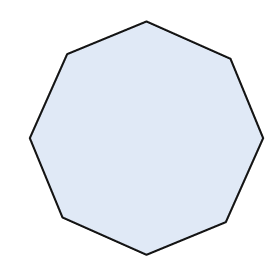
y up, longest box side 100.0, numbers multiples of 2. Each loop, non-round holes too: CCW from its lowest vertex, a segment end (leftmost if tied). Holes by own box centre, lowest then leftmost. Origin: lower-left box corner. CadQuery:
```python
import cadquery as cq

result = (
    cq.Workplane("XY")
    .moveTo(50.0, 0.0)
    .lineTo(84.0, 14.0)
    .lineTo(100.0, 50.0)
    .lineTo(86.0, 84.0)
    .lineTo(50.0, 100.0)
    .lineTo(16.0, 86.0)
    .lineTo(0.0, 50.0)
    .lineTo(14.0, 16.0)
    .close()
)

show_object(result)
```